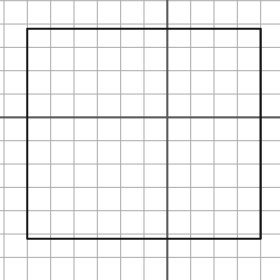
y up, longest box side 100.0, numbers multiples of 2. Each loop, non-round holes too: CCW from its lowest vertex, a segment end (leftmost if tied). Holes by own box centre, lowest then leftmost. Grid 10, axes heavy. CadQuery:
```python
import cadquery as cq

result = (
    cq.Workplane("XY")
    .moveTo(-60.0, -52.0)
    .lineTo(40.0, -52.0)
    .lineTo(40.0, 38.0)
    .lineTo(-60.0, 38.0)
    .close()
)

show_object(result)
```